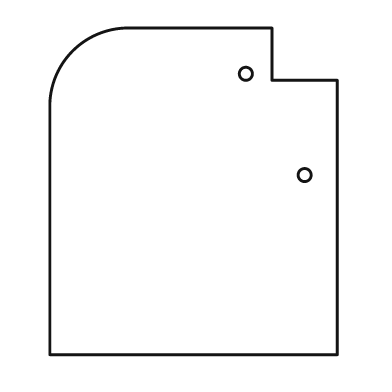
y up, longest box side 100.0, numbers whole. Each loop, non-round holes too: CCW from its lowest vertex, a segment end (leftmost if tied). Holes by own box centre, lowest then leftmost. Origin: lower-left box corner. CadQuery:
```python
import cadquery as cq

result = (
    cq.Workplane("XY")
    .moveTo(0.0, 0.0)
    .lineTo(88.0, 0.0)
    .lineTo(88.0, 84.0)
    .lineTo(68.0, 84.0)
    .lineTo(68.0, 100.0)
    .lineTo(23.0, 100.0)
    .threePointArc((7.0, 93.0), (0.0, 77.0))
    .close()
    .moveTo(78.0, 55.0)
    .circle(2.0)
    .moveTo(60.0, 86.0)
    .circle(2.0)
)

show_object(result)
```